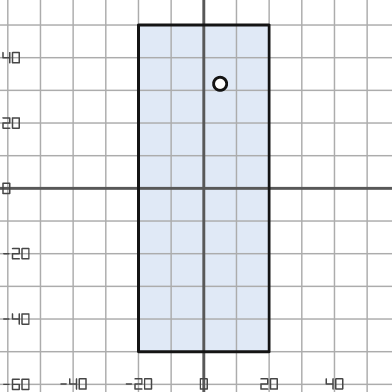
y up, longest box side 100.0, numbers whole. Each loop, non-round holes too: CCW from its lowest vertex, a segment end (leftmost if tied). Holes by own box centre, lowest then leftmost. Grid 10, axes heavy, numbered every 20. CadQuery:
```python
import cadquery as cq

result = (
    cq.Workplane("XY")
    .moveTo(-20.0, -50.0)
    .lineTo(20.0, -50.0)
    .lineTo(20.0, 50.0)
    .lineTo(-20.0, 50.0)
    .close()
    .moveTo(5.0, 32.0)
    .circle(2.0)
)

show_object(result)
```